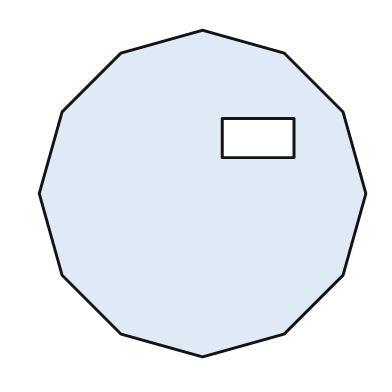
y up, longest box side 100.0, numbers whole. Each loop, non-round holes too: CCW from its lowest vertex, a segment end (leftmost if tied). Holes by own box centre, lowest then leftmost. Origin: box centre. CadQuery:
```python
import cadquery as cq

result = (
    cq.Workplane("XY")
    .moveTo(0.0, -50.0)
    .lineTo(25.0, -43.0)
    .lineTo(43.0, -25.0)
    .lineTo(50.0, 0.0)
    .lineTo(43.0, 25.0)
    .lineTo(25.0, 43.0)
    .lineTo(0.0, 50.0)
    .lineTo(-25.0, 43.0)
    .lineTo(-43.0, 25.0)
    .lineTo(-50.0, 0.0)
    .lineTo(-43.0, -25.0)
    .lineTo(-25.0, -43.0)
    .close()
    .moveTo(6.0, 11.0)
    .lineTo(28.0, 11.0)
    .lineTo(28.0, 23.0)
    .lineTo(6.0, 23.0)
    .close()
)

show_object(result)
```